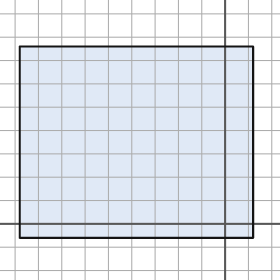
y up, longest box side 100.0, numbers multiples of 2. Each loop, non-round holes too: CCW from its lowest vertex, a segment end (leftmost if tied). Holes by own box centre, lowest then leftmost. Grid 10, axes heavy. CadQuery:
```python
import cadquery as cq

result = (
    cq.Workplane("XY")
    .moveTo(-88.0, -6.0)
    .lineTo(12.0, -6.0)
    .lineTo(12.0, 76.0)
    .lineTo(-88.0, 76.0)
    .close()
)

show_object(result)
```